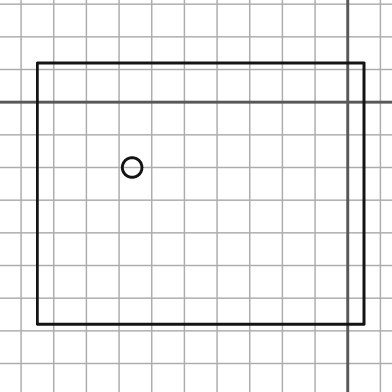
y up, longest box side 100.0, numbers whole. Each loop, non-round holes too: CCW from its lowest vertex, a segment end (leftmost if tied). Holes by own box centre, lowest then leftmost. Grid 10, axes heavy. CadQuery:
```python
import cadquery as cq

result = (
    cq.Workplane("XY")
    .moveTo(-95.0, -68.0)
    .lineTo(5.0, -68.0)
    .lineTo(5.0, 12.0)
    .lineTo(-95.0, 12.0)
    .close()
    .moveTo(-66.0, -20.0)
    .circle(3.0)
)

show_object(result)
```